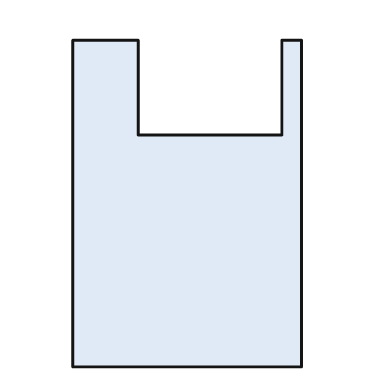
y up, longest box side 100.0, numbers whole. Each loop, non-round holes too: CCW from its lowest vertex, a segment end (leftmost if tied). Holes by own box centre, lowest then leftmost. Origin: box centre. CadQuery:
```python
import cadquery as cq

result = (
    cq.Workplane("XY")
    .moveTo(-35.0, -50.0)
    .lineTo(35.0, -50.0)
    .lineTo(35.0, 50.0)
    .lineTo(29.0, 50.0)
    .lineTo(29.0, 21.0)
    .lineTo(-15.0, 21.0)
    .lineTo(-15.0, 50.0)
    .lineTo(-35.0, 50.0)
    .close()
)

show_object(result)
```